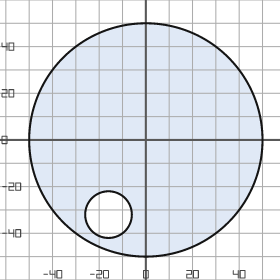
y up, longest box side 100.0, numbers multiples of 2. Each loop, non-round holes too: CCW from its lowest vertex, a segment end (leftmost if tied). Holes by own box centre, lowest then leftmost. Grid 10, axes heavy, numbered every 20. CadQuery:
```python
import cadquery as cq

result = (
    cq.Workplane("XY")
    .moveTo(0.0, 0.0)
    .circle(50.0)
    .moveTo(-16.0, -32.0)
    .circle(10.0)
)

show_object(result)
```